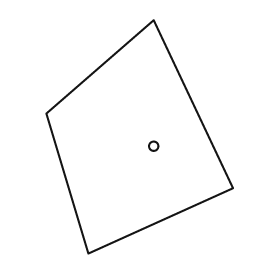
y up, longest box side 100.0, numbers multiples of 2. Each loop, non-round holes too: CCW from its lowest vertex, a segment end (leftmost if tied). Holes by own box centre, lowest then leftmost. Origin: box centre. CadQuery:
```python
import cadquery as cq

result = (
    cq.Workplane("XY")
    .moveTo(-22.0, -50.0)
    .lineTo(40.0, -22.0)
    .lineTo(6.0, 50.0)
    .lineTo(-40.0, 10.0)
    .close()
    .moveTo(6.0, -4.0)
    .circle(2.0)
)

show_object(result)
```